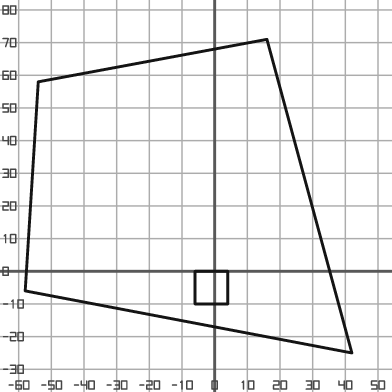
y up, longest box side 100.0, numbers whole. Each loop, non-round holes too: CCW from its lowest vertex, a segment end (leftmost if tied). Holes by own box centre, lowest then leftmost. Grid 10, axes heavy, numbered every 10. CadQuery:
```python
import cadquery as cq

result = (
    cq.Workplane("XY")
    .moveTo(42.0, -25.0)
    .lineTo(16.0, 71.0)
    .lineTo(-54.0, 58.0)
    .lineTo(-58.0, -6.0)
    .close()
    .moveTo(-6.0, -10.0)
    .lineTo(4.0, -10.0)
    .lineTo(4.0, 0.0)
    .lineTo(-6.0, 0.0)
    .close()
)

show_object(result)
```